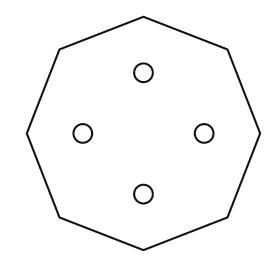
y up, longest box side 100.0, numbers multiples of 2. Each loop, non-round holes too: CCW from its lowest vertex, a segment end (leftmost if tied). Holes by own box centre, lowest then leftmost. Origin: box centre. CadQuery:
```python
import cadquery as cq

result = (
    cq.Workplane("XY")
    .moveTo(0.0, -50.0)
    .lineTo(36.0, -36.0)
    .lineTo(50.0, 0.0)
    .lineTo(36.0, 36.0)
    .lineTo(0.0, 50.0)
    .lineTo(-36.0, 36.0)
    .lineTo(-50.0, 0.0)
    .lineTo(-36.0, -36.0)
    .close()
    .moveTo(0.0, -26.0)
    .circle(4.0)
    .moveTo(-26.0, 0.0)
    .circle(4.0)
    .moveTo(26.0, 0.0)
    .circle(4.0)
    .moveTo(0.0, 26.0)
    .circle(4.0)
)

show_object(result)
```